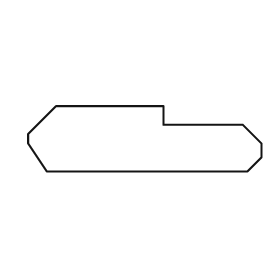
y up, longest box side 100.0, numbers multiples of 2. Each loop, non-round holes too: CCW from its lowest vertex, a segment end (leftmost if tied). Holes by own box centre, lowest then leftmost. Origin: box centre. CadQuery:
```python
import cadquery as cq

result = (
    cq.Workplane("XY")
    .moveTo(-42.0, -14.0)
    .lineTo(44.0, -14.0)
    .lineTo(50.0, -8.0)
    .lineTo(50.0, -2.0)
    .lineTo(42.0, 6.0)
    .lineTo(8.0, 6.0)
    .lineTo(8.0, 14.0)
    .lineTo(-38.0, 14.0)
    .lineTo(-50.0, 2.0)
    .lineTo(-50.0, -2.0)
    .close()
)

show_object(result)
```